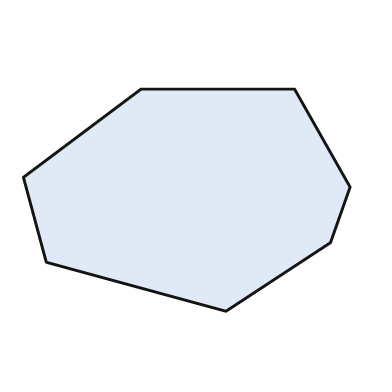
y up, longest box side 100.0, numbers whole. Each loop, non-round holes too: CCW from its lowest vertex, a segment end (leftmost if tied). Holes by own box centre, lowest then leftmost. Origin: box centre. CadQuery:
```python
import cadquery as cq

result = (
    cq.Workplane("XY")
    .moveTo(12.0, -34.0)
    .lineTo(44.0, -13.0)
    .lineTo(50.0, 4.0)
    .lineTo(33.0, 34.0)
    .lineTo(-14.0, 34.0)
    .lineTo(-50.0, 7.0)
    .lineTo(-43.0, -19.0)
    .close()
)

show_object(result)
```